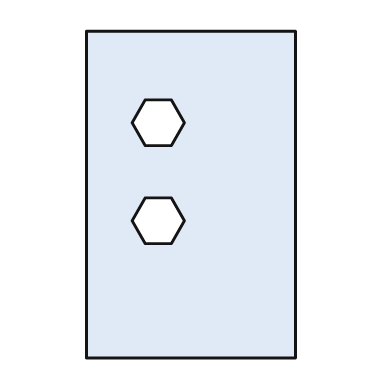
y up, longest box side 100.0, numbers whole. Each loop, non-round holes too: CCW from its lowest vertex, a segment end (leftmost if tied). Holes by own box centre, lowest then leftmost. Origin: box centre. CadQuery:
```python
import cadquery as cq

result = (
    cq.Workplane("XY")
    .moveTo(-32.0, -50.0)
    .lineTo(32.0, -50.0)
    .lineTo(32.0, 50.0)
    .lineTo(-32.0, 50.0)
    .close()
    .moveTo(-14.0, -15.0)
    .lineTo(-6.0, -15.0)
    .lineTo(-2.0, -8.0)
    .lineTo(-6.0, -1.0)
    .lineTo(-14.0, -1.0)
    .lineTo(-18.0, -8.0)
    .close()
    .moveTo(-14.0, 15.0)
    .lineTo(-6.0, 15.0)
    .lineTo(-2.0, 22.0)
    .lineTo(-6.0, 29.0)
    .lineTo(-14.0, 29.0)
    .lineTo(-18.0, 22.0)
    .close()
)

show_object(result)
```